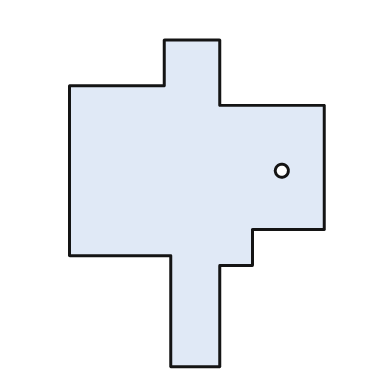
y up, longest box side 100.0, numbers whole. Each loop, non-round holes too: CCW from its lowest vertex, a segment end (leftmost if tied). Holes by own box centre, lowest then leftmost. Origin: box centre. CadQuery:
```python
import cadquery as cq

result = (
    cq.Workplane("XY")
    .moveTo(-8.0, -50.0)
    .lineTo(7.0, -50.0)
    .lineTo(7.0, -19.0)
    .lineTo(17.0, -19.0)
    .lineTo(17.0, -8.0)
    .lineTo(39.0, -8.0)
    .lineTo(39.0, 30.0)
    .lineTo(7.0, 30.0)
    .lineTo(7.0, 50.0)
    .lineTo(-10.0, 50.0)
    .lineTo(-10.0, 36.0)
    .lineTo(-39.0, 36.0)
    .lineTo(-39.0, -16.0)
    .lineTo(-8.0, -16.0)
    .close()
    .moveTo(26.0, 10.0)
    .circle(2.0)
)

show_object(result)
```